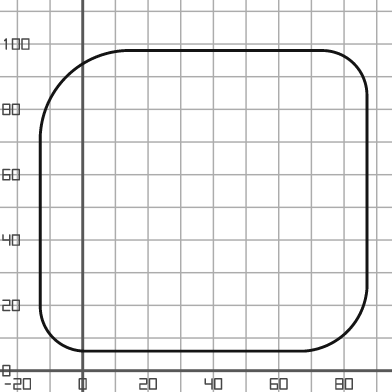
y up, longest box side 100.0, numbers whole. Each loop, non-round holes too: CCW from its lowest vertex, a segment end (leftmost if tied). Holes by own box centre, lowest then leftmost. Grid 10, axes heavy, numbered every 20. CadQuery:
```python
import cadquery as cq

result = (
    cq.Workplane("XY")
    .moveTo(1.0, 6.0)
    .lineTo(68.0, 6.0)
    .threePointArc((81.0, 12.0), (87.0, 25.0))
    .lineTo(87.0, 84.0)
    .threePointArc((83.0, 94.0), (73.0, 98.0))
    .lineTo(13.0, 98.0)
    .threePointArc((-5.0, 90.0), (-13.0, 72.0))
    .lineTo(-13.0, 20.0)
    .threePointArc((-9.0, 10.0), (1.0, 6.0))
    .close()
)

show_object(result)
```